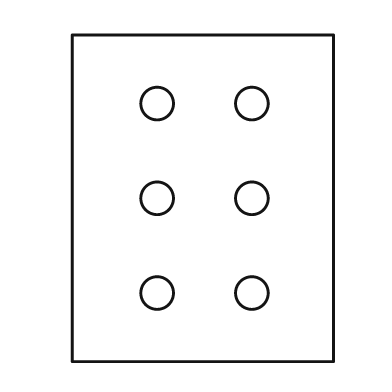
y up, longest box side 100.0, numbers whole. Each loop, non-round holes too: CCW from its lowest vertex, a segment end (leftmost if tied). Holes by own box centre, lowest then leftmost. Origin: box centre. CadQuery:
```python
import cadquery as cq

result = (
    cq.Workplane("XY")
    .moveTo(-40.0, -50.0)
    .lineTo(40.0, -50.0)
    .lineTo(40.0, 50.0)
    .lineTo(-40.0, 50.0)
    .close()
    .moveTo(-14.0, -29.0)
    .circle(5.0)
    .moveTo(15.0, -29.0)
    .circle(5.0)
    .moveTo(-14.0, 0.0)
    .circle(5.0)
    .moveTo(15.0, 0.0)
    .circle(5.0)
    .moveTo(-14.0, 29.0)
    .circle(5.0)
    .moveTo(15.0, 29.0)
    .circle(5.0)
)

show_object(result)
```